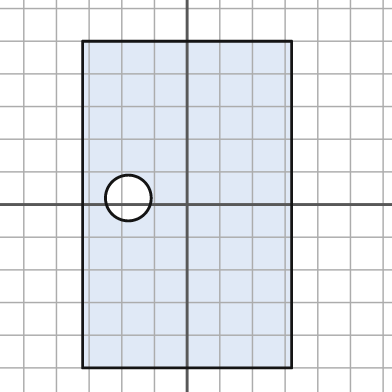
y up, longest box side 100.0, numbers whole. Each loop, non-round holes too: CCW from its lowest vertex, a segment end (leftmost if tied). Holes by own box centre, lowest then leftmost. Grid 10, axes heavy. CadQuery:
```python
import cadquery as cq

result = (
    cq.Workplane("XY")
    .moveTo(-32.0, -50.0)
    .lineTo(32.0, -50.0)
    .lineTo(32.0, 50.0)
    .lineTo(-32.0, 50.0)
    .close()
    .moveTo(-18.0, 2.0)
    .circle(7.0)
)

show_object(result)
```